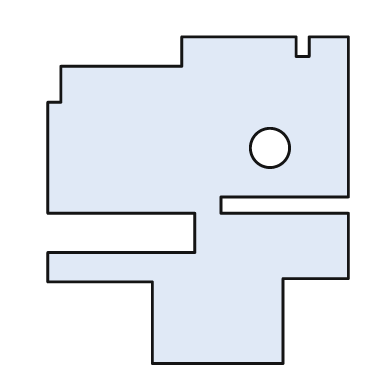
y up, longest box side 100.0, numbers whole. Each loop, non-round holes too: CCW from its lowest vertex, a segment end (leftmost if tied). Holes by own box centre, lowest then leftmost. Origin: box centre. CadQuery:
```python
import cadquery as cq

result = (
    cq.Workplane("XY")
    .moveTo(-14.0, -50.0)
    .lineTo(26.0, -50.0)
    .lineTo(26.0, -24.0)
    .lineTo(46.0, -24.0)
    .lineTo(46.0, -4.0)
    .lineTo(7.0, -4.0)
    .lineTo(7.0, 1.0)
    .lineTo(46.0, 1.0)
    .lineTo(46.0, 50.0)
    .lineTo(34.0, 50.0)
    .lineTo(34.0, 44.0)
    .lineTo(30.0, 44.0)
    .lineTo(30.0, 50.0)
    .lineTo(-5.0, 50.0)
    .lineTo(-5.0, 41.0)
    .lineTo(-42.0, 41.0)
    .lineTo(-42.0, 30.0)
    .lineTo(-46.0, 30.0)
    .lineTo(-46.0, -4.0)
    .lineTo(-1.0, -4.0)
    .lineTo(-1.0, -16.0)
    .lineTo(-46.0, -16.0)
    .lineTo(-46.0, -25.0)
    .lineTo(-14.0, -25.0)
    .close()
    .moveTo(22.0, 16.0)
    .circle(6.0)
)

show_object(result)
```